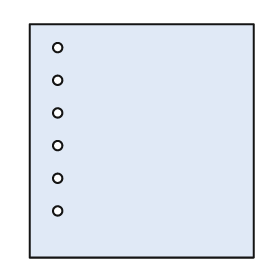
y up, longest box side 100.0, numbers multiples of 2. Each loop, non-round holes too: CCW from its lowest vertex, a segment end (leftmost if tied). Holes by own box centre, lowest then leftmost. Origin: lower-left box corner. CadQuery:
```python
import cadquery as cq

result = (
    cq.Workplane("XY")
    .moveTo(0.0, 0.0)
    .lineTo(96.0, 0.0)
    .lineTo(96.0, 100.0)
    .lineTo(0.0, 100.0)
    .close()
    .moveTo(12.0, 20.0)
    .circle(2.0)
    .moveTo(12.0, 34.0)
    .circle(2.0)
    .moveTo(12.0, 48.0)
    .circle(2.0)
    .moveTo(12.0, 62.0)
    .circle(2.0)
    .moveTo(12.0, 76.0)
    .circle(2.0)
    .moveTo(12.0, 90.0)
    .circle(2.0)
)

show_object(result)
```